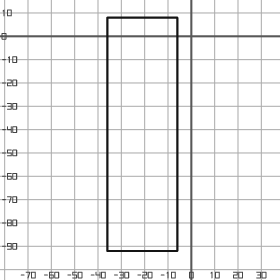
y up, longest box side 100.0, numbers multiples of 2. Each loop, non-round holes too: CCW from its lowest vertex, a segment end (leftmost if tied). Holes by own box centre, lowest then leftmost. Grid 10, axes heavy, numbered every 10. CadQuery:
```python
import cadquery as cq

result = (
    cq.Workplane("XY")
    .moveTo(-36.0, -92.0)
    .lineTo(-6.0, -92.0)
    .lineTo(-6.0, 8.0)
    .lineTo(-36.0, 8.0)
    .close()
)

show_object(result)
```